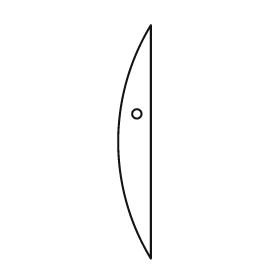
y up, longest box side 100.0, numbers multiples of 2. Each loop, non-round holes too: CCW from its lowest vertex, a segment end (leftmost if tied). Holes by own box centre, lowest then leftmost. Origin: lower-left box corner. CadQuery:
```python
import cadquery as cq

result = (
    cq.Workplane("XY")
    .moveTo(14.0, 0.0)
    .lineTo(14.0, 100.0)
    .threePointArc((0.0, 50.0), (14.0, 0.0))
    .close()
    .moveTo(8.0, 62.0)
    .circle(2.0)
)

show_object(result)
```